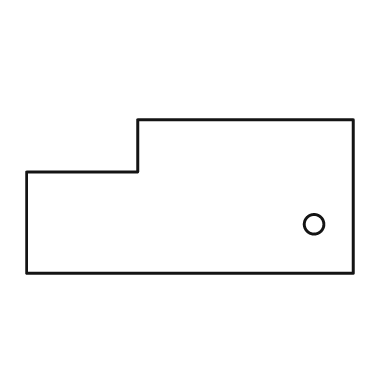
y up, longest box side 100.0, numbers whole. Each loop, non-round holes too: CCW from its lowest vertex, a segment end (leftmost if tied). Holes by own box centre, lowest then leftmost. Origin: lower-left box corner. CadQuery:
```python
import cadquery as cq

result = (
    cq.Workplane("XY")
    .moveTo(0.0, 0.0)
    .lineTo(100.0, 0.0)
    .lineTo(100.0, 47.0)
    .lineTo(34.0, 47.0)
    .lineTo(34.0, 31.0)
    .lineTo(0.0, 31.0)
    .close()
    .moveTo(88.0, 15.0)
    .circle(3.0)
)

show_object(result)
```